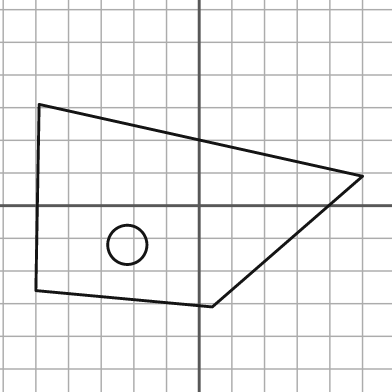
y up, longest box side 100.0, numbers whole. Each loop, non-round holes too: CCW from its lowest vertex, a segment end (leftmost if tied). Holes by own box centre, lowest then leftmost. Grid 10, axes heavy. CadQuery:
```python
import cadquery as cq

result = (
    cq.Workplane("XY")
    .moveTo(4.0, -31.0)
    .lineTo(50.0, 9.0)
    .lineTo(-49.0, 31.0)
    .lineTo(-50.0, -26.0)
    .close()
    .moveTo(-22.0, -12.0)
    .circle(6.0)
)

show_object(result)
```